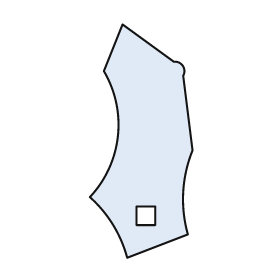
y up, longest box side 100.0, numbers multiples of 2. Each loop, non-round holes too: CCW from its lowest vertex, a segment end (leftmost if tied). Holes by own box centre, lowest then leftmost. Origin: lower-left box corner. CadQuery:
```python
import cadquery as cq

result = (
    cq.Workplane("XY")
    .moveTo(16.0, 0.0)
    .lineTo(42.0, 10.0)
    .threePointArc((40.0, 28.0), (44.0, 46.0))
    .lineTo(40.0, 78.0)
    .threePointArc((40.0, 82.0), (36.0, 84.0))
    .lineTo(14.0, 100.0)
    .lineTo(6.0, 80.0)
    .threePointArc((12.0, 52.0), (0.0, 26.0))
    .threePointArc((10.0, 14.0), (16.0, 0.0))
    .close()
    .moveTo(20.0, 14.0)
    .lineTo(28.0, 14.0)
    .lineTo(28.0, 22.0)
    .lineTo(20.0, 22.0)
    .close()
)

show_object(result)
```